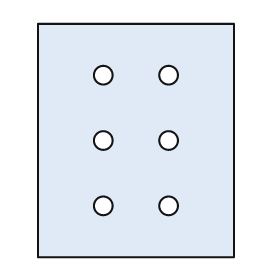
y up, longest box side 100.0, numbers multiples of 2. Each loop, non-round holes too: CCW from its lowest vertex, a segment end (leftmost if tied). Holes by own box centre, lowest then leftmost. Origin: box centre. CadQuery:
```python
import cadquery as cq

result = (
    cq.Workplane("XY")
    .moveTo(-42.0, -50.0)
    .lineTo(42.0, -50.0)
    .lineTo(42.0, 50.0)
    .lineTo(-42.0, 50.0)
    .close()
    .moveTo(-14.0, -28.0)
    .circle(4.0)
    .moveTo(14.0, -28.0)
    .circle(4.0)
    .moveTo(-14.0, 0.0)
    .circle(4.0)
    .moveTo(14.0, 0.0)
    .circle(4.0)
    .moveTo(-14.0, 28.0)
    .circle(4.0)
    .moveTo(14.0, 28.0)
    .circle(4.0)
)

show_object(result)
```